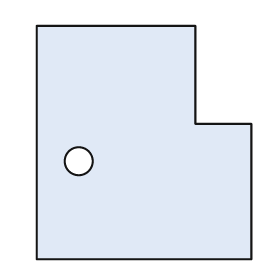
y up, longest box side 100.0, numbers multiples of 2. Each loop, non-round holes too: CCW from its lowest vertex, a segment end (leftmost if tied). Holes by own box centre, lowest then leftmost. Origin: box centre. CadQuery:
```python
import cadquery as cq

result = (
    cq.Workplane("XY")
    .moveTo(-46.0, -50.0)
    .lineTo(46.0, -50.0)
    .lineTo(46.0, 8.0)
    .lineTo(22.0, 8.0)
    .lineTo(22.0, 50.0)
    .lineTo(-46.0, 50.0)
    .close()
    .moveTo(-28.0, -8.0)
    .circle(6.0)
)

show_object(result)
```